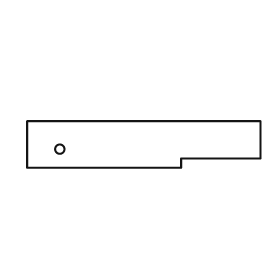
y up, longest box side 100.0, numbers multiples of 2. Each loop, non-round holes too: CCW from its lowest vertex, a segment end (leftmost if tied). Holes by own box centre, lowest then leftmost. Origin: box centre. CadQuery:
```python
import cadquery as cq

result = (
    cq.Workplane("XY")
    .moveTo(-50.0, -10.0)
    .lineTo(16.0, -10.0)
    .lineTo(16.0, -6.0)
    .lineTo(50.0, -6.0)
    .lineTo(50.0, 10.0)
    .lineTo(-50.0, 10.0)
    .close()
    .moveTo(-36.0, -2.0)
    .circle(2.0)
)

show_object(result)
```